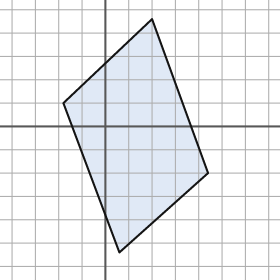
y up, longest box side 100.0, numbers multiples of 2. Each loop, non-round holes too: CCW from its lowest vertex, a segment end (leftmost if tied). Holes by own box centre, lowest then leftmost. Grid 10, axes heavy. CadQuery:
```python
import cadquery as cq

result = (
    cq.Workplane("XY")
    .moveTo(6.0, -54.0)
    .lineTo(44.0, -20.0)
    .lineTo(20.0, 46.0)
    .lineTo(-18.0, 10.0)
    .close()
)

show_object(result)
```